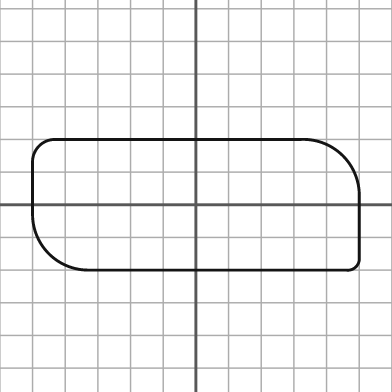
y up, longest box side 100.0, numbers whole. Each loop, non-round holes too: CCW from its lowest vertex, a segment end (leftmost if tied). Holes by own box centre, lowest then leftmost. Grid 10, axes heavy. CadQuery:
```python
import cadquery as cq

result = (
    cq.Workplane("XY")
    .moveTo(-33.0, -20.0)
    .lineTo(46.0, -20.0)
    .threePointArc((49.0, -19.0), (50.0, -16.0))
    .lineTo(50.0, 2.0)
    .threePointArc((45.0, 15.0), (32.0, 20.0))
    .lineTo(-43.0, 20.0)
    .threePointArc((-48.0, 18.0), (-50.0, 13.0))
    .lineTo(-50.0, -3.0)
    .threePointArc((-45.0, -15.0), (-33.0, -20.0))
    .close()
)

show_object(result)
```